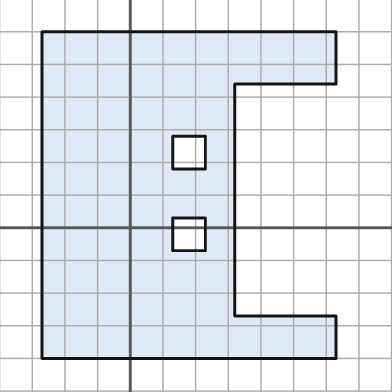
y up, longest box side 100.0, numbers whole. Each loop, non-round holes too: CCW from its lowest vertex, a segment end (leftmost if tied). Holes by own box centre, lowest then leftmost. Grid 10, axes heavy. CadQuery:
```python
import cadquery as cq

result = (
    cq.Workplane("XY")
    .moveTo(-27.0, -40.0)
    .lineTo(63.0, -40.0)
    .lineTo(63.0, -27.0)
    .lineTo(32.0, -27.0)
    .lineTo(32.0, 44.0)
    .lineTo(63.0, 44.0)
    .lineTo(63.0, 60.0)
    .lineTo(-27.0, 60.0)
    .close()
    .moveTo(13.0, -7.0)
    .lineTo(23.0, -7.0)
    .lineTo(23.0, 3.0)
    .lineTo(13.0, 3.0)
    .close()
    .moveTo(13.0, 18.0)
    .lineTo(23.0, 18.0)
    .lineTo(23.0, 28.0)
    .lineTo(13.0, 28.0)
    .close()
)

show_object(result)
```